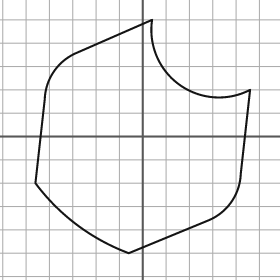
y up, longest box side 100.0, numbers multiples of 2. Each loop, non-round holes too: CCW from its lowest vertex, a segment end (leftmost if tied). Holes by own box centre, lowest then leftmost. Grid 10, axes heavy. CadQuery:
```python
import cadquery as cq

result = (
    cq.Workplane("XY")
    .moveTo(-6.0, -50.0)
    .lineTo(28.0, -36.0)
    .threePointArc((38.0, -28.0), (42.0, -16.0))
    .lineTo(46.0, 20.0)
    .threePointArc((16.0, 22.0), (4.0, 50.0))
    .lineTo(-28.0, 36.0)
    .threePointArc((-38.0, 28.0), (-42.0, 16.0))
    .lineTo(-46.0, -20.0)
    .threePointArc((-28.0, -38.0), (-6.0, -50.0))
    .close()
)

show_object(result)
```